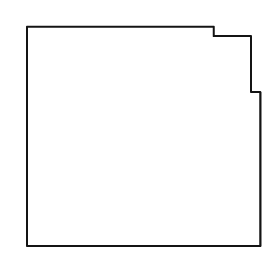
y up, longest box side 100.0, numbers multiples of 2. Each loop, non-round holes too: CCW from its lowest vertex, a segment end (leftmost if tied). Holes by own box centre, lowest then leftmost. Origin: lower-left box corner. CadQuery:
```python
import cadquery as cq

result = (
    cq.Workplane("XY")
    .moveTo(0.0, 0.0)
    .lineTo(100.0, 0.0)
    .lineTo(100.0, 66.0)
    .lineTo(96.0, 66.0)
    .lineTo(96.0, 90.0)
    .lineTo(80.0, 90.0)
    .lineTo(80.0, 94.0)
    .lineTo(0.0, 94.0)
    .close()
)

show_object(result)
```